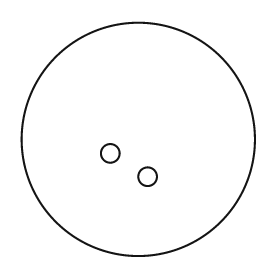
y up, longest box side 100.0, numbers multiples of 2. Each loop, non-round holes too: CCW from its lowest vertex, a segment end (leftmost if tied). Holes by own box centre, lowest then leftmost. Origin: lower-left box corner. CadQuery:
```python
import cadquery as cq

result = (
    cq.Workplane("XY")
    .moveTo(50.0, 50.0)
    .circle(50.0)
    .moveTo(54.0, 34.0)
    .circle(4.0)
    .moveTo(38.0, 44.0)
    .circle(4.0)
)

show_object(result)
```